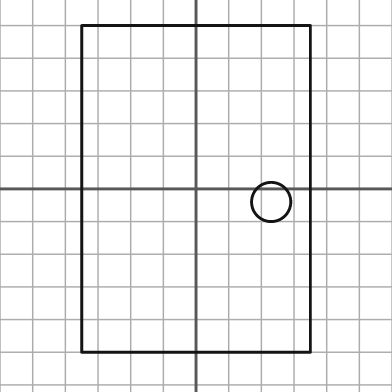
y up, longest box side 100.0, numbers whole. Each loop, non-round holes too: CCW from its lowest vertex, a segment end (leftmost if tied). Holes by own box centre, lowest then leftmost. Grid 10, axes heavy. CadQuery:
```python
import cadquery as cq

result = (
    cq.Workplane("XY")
    .moveTo(-35.0, -50.0)
    .lineTo(35.0, -50.0)
    .lineTo(35.0, 50.0)
    .lineTo(-35.0, 50.0)
    .close()
    .moveTo(23.0, -4.0)
    .circle(6.0)
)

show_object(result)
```